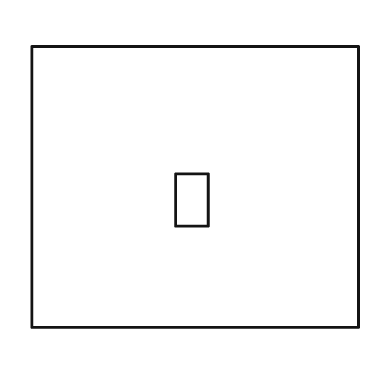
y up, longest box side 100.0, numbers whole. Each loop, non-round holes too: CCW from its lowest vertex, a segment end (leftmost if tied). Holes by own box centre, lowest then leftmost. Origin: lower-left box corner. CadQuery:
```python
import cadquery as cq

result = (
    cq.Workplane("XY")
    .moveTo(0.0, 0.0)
    .lineTo(100.0, 0.0)
    .lineTo(100.0, 86.0)
    .lineTo(0.0, 86.0)
    .close()
    .moveTo(44.0, 31.0)
    .lineTo(54.0, 31.0)
    .lineTo(54.0, 47.0)
    .lineTo(44.0, 47.0)
    .close()
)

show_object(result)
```